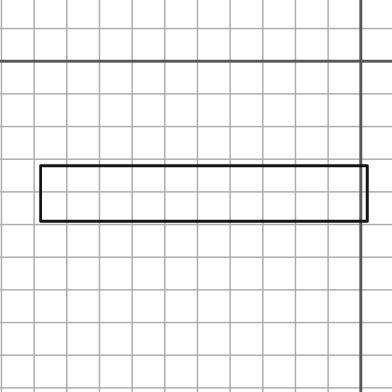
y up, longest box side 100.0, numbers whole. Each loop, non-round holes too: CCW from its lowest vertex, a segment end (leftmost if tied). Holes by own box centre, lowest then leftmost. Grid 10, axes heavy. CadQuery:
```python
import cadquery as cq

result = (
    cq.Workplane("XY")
    .moveTo(-98.0, -49.0)
    .lineTo(2.0, -49.0)
    .lineTo(2.0, -32.0)
    .lineTo(-98.0, -32.0)
    .close()
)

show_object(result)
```